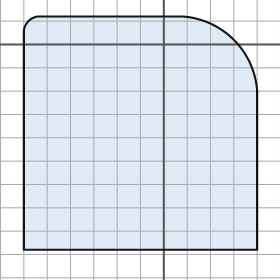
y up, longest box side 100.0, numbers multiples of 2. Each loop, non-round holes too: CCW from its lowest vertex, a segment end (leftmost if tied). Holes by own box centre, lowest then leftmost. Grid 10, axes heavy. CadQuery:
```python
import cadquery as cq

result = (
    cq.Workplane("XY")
    .moveTo(-60.0, -88.0)
    .lineTo(40.0, -88.0)
    .lineTo(40.0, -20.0)
    .threePointArc((30.0, 2.0), (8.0, 12.0))
    .lineTo(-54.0, 12.0)
    .threePointArc((-58.0, 10.0), (-60.0, 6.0))
    .close()
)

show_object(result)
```